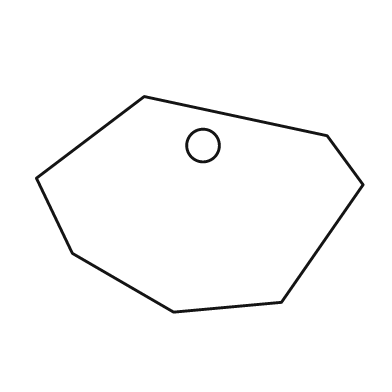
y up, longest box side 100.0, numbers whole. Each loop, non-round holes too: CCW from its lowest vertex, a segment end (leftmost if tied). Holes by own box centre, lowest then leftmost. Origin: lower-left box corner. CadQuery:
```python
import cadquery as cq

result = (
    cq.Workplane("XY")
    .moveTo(42.0, 0.0)
    .lineTo(75.0, 3.0)
    .lineTo(100.0, 39.0)
    .lineTo(89.0, 54.0)
    .lineTo(33.0, 66.0)
    .lineTo(0.0, 41.0)
    .lineTo(11.0, 18.0)
    .close()
    .moveTo(51.0, 51.0)
    .circle(5.0)
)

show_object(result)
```